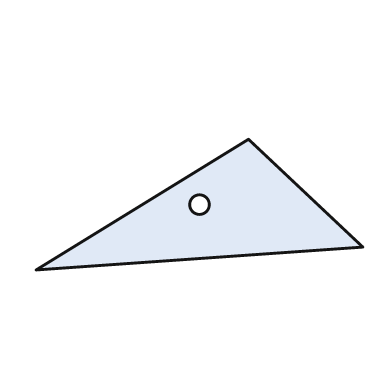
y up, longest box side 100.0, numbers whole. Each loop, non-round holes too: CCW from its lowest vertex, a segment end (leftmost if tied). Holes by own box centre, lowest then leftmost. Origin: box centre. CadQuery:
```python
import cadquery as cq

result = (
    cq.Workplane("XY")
    .moveTo(-50.0, -20.0)
    .lineTo(50.0, -13.0)
    .lineTo(15.0, 20.0)
    .close()
    .moveTo(0.0, 0.0)
    .circle(3.0)
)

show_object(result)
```